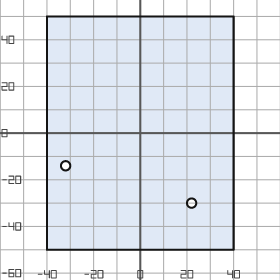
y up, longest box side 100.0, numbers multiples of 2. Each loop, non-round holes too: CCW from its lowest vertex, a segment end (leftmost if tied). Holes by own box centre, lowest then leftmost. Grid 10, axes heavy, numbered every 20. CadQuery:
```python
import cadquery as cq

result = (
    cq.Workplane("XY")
    .moveTo(-40.0, -50.0)
    .lineTo(40.0, -50.0)
    .lineTo(40.0, 50.0)
    .lineTo(-40.0, 50.0)
    .close()
    .moveTo(22.0, -30.0)
    .circle(2.0)
    .moveTo(-32.0, -14.0)
    .circle(2.0)
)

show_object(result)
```